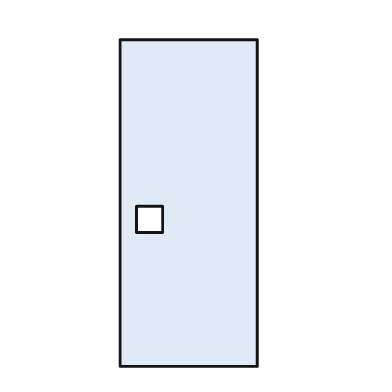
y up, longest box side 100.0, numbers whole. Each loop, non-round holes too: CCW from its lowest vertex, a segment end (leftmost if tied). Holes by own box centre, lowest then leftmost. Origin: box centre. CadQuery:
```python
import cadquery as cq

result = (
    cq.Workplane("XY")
    .moveTo(-21.0, -50.0)
    .lineTo(21.0, -50.0)
    .lineTo(21.0, 50.0)
    .lineTo(-21.0, 50.0)
    .close()
    .moveTo(-16.0, -9.0)
    .lineTo(-8.0, -9.0)
    .lineTo(-8.0, -1.0)
    .lineTo(-16.0, -1.0)
    .close()
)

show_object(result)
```